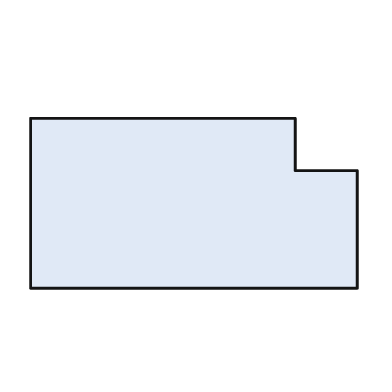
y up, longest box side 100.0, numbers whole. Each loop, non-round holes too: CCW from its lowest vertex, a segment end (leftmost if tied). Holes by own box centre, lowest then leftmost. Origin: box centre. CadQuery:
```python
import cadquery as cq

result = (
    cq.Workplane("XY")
    .moveTo(-50.0, -26.0)
    .lineTo(50.0, -26.0)
    .lineTo(50.0, 10.0)
    .lineTo(31.0, 10.0)
    .lineTo(31.0, 26.0)
    .lineTo(-50.0, 26.0)
    .close()
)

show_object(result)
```